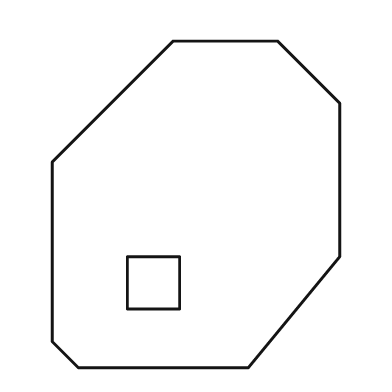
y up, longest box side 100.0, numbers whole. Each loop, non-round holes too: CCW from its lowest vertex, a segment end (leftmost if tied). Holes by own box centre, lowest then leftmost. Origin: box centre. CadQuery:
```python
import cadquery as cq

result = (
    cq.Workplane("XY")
    .moveTo(-36.0, -50.0)
    .lineTo(16.0, -50.0)
    .lineTo(44.0, -16.0)
    .lineTo(44.0, 31.0)
    .lineTo(25.0, 50.0)
    .lineTo(-7.0, 50.0)
    .lineTo(-44.0, 13.0)
    .lineTo(-44.0, -42.0)
    .close()
    .moveTo(-21.0, -32.0)
    .lineTo(-5.0, -32.0)
    .lineTo(-5.0, -16.0)
    .lineTo(-21.0, -16.0)
    .close()
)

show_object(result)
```